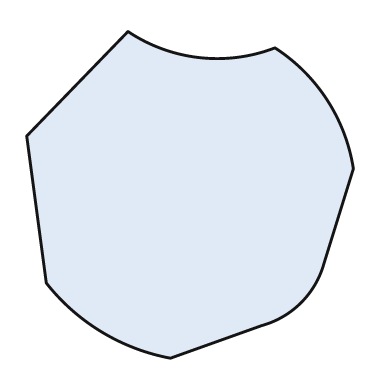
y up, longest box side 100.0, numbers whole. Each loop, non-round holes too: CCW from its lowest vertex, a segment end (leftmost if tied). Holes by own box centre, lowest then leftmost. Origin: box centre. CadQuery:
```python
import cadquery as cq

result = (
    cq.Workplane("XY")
    .moveTo(-6.0, -50.0)
    .lineTo(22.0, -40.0)
    .threePointArc((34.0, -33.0), (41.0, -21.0))
    .lineTo(50.0, 8.0)
    .threePointArc((42.0, 29.0), (26.0, 45.0))
    .threePointArc((3.0, 42.0), (-19.0, 50.0))
    .lineTo(-50.0, 18.0)
    .lineTo(-44.0, -27.0)
    .threePointArc((-27.0, -42.0), (-6.0, -50.0))
    .close()
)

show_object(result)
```